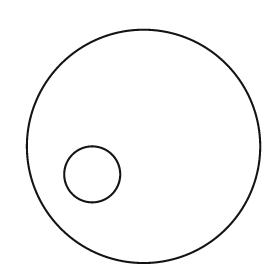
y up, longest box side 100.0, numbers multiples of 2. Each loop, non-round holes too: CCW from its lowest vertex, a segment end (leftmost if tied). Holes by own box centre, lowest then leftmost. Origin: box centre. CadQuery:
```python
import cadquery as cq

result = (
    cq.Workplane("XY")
    .moveTo(0.0, 0.0)
    .circle(50.0)
    .moveTo(-22.0, -12.0)
    .circle(12.0)
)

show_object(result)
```